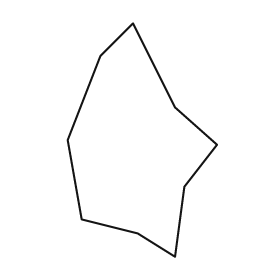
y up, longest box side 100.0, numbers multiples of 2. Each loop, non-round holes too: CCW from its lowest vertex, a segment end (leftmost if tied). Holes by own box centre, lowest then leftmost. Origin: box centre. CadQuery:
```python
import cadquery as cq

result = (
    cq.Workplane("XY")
    .moveTo(14.0, -50.0)
    .lineTo(18.0, -20.0)
    .lineTo(32.0, -2.0)
    .lineTo(14.0, 14.0)
    .lineTo(-4.0, 50.0)
    .lineTo(-18.0, 36.0)
    .lineTo(-32.0, 0.0)
    .lineTo(-26.0, -34.0)
    .lineTo(-2.0, -40.0)
    .close()
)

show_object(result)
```